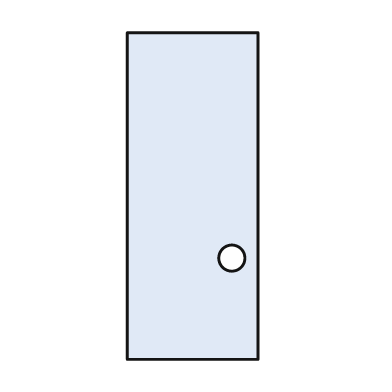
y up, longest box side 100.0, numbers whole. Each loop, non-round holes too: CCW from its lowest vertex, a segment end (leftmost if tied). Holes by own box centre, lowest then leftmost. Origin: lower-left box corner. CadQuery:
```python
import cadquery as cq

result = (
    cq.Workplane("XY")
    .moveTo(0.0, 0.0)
    .lineTo(40.0, 0.0)
    .lineTo(40.0, 100.0)
    .lineTo(0.0, 100.0)
    .close()
    .moveTo(32.0, 31.0)
    .circle(4.0)
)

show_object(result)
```